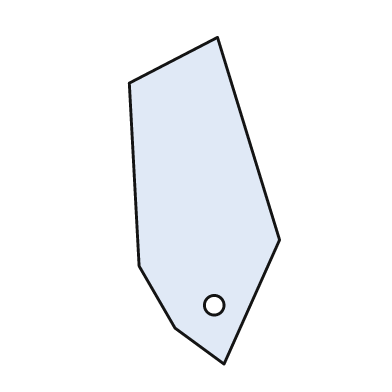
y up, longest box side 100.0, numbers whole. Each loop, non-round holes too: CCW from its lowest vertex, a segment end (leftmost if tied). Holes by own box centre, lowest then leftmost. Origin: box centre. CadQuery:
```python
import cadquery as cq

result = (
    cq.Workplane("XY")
    .moveTo(6.0, -50.0)
    .lineTo(23.0, -12.0)
    .lineTo(4.0, 50.0)
    .lineTo(-23.0, 36.0)
    .lineTo(-20.0, -20.0)
    .lineTo(-9.0, -39.0)
    .close()
    .moveTo(3.0, -32.0)
    .circle(3.0)
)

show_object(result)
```